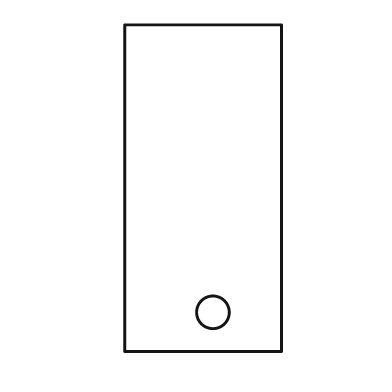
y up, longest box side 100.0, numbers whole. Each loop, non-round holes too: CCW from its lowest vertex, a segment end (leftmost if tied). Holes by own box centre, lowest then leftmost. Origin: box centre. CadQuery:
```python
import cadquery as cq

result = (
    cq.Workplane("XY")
    .moveTo(-24.0, -50.0)
    .lineTo(24.0, -50.0)
    .lineTo(24.0, 50.0)
    .lineTo(-24.0, 50.0)
    .close()
    .moveTo(3.0, -38.0)
    .circle(5.0)
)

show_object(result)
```